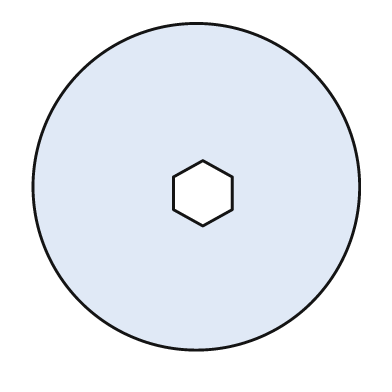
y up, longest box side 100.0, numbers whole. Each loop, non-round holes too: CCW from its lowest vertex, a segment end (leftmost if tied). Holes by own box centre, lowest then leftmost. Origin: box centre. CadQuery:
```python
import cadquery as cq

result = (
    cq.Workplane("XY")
    .moveTo(0.0, 0.0)
    .circle(50.0)
    .moveTo(2.0, -12.0)
    .lineTo(11.0, -7.0)
    .lineTo(11.0, 3.0)
    .lineTo(2.0, 8.0)
    .lineTo(-7.0, 3.0)
    .lineTo(-7.0, -7.0)
    .close()
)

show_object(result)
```